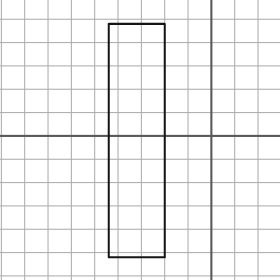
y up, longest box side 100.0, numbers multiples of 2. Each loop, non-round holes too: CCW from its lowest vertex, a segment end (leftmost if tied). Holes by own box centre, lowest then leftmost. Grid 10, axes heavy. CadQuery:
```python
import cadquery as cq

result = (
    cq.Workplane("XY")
    .moveTo(-44.0, -52.0)
    .lineTo(-20.0, -52.0)
    .lineTo(-20.0, 48.0)
    .lineTo(-44.0, 48.0)
    .close()
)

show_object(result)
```